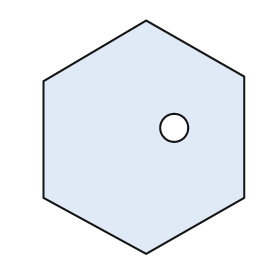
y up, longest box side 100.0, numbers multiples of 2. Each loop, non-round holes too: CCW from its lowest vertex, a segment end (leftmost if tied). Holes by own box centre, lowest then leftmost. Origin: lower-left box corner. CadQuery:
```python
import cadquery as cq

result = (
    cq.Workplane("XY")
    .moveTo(44.0, 0.0)
    .lineTo(86.0, 24.0)
    .lineTo(86.0, 76.0)
    .lineTo(44.0, 100.0)
    .lineTo(0.0, 74.0)
    .lineTo(0.0, 24.0)
    .close()
    .moveTo(56.0, 54.0)
    .circle(6.0)
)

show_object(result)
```